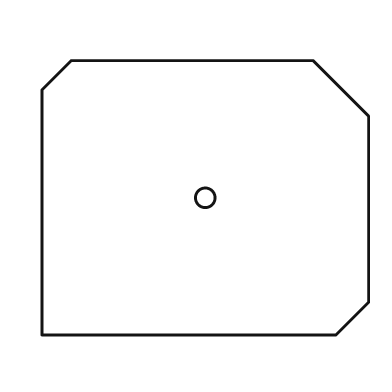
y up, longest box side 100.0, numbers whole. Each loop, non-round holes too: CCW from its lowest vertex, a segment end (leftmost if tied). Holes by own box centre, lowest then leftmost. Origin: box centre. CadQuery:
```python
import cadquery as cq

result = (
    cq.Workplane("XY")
    .moveTo(-50.0, -42.0)
    .lineTo(40.0, -42.0)
    .lineTo(50.0, -32.0)
    .lineTo(50.0, 25.0)
    .lineTo(33.0, 42.0)
    .lineTo(-41.0, 42.0)
    .lineTo(-50.0, 33.0)
    .close()
    .moveTo(0.0, 0.0)
    .circle(3.0)
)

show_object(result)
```